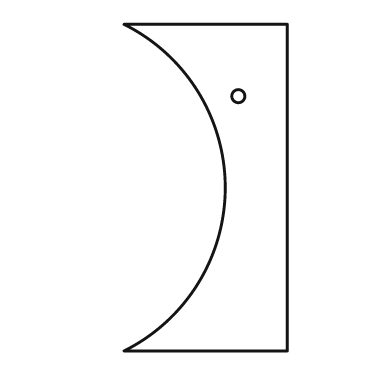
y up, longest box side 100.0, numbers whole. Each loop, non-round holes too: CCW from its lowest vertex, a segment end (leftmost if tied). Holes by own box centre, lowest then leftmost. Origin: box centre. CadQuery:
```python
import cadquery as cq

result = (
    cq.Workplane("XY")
    .moveTo(-25.0, -50.0)
    .lineTo(25.0, -50.0)
    .lineTo(25.0, 50.0)
    .lineTo(-25.0, 50.0)
    .threePointArc((6.0, 0.0), (-25.0, -50.0))
    .close()
    .moveTo(10.0, 28.0)
    .circle(2.0)
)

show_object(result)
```